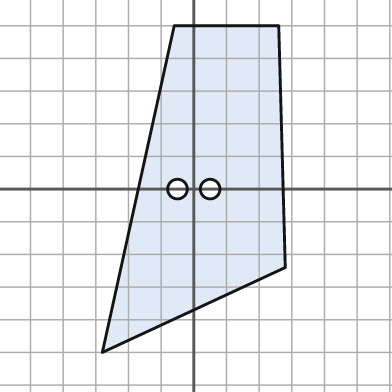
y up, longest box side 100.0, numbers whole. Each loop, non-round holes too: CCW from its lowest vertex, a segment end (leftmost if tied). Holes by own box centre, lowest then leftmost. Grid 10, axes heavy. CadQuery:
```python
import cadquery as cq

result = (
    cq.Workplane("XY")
    .moveTo(-28.0, -50.0)
    .lineTo(28.0, -24.0)
    .lineTo(26.0, 50.0)
    .lineTo(-6.0, 50.0)
    .close()
    .moveTo(-5.0, 0.0)
    .circle(3.0)
    .moveTo(5.0, 0.0)
    .circle(3.0)
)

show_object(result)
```